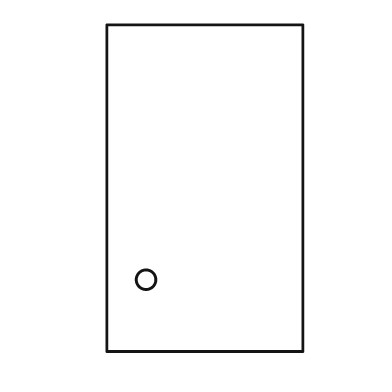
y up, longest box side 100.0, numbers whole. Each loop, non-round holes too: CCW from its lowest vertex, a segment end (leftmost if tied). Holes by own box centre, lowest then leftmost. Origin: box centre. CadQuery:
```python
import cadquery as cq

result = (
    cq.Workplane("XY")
    .moveTo(-30.0, -50.0)
    .lineTo(30.0, -50.0)
    .lineTo(30.0, 50.0)
    .lineTo(-30.0, 50.0)
    .close()
    .moveTo(-18.0, -28.0)
    .circle(3.0)
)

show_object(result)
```